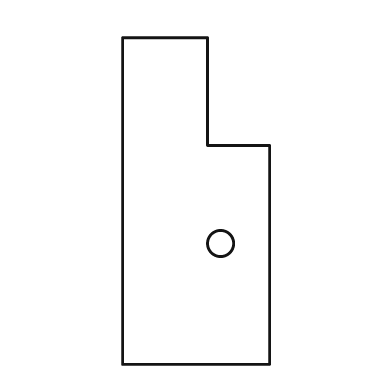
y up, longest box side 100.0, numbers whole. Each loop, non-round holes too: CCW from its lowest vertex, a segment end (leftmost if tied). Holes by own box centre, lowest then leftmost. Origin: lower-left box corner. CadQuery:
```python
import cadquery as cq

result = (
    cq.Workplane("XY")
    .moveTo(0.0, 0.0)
    .lineTo(45.0, 0.0)
    .lineTo(45.0, 67.0)
    .lineTo(26.0, 67.0)
    .lineTo(26.0, 100.0)
    .lineTo(0.0, 100.0)
    .close()
    .moveTo(30.0, 37.0)
    .circle(4.0)
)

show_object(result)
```